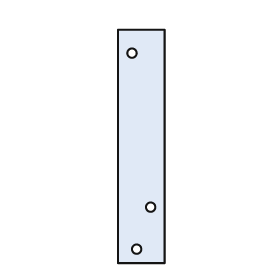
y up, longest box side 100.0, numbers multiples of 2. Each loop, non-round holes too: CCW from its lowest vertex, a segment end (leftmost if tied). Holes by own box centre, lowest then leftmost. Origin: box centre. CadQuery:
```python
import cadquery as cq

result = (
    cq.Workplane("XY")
    .moveTo(-10.0, -50.0)
    .lineTo(10.0, -50.0)
    .lineTo(10.0, 50.0)
    .lineTo(-10.0, 50.0)
    .close()
    .moveTo(-2.0, -44.0)
    .circle(2.0)
    .moveTo(4.0, -26.0)
    .circle(2.0)
    .moveTo(-4.0, 40.0)
    .circle(2.0)
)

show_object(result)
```